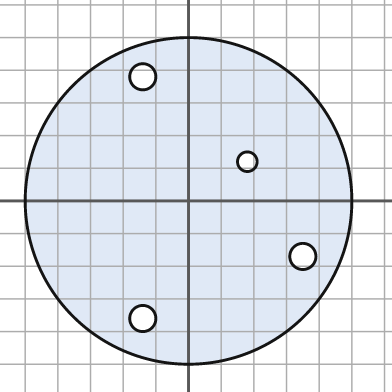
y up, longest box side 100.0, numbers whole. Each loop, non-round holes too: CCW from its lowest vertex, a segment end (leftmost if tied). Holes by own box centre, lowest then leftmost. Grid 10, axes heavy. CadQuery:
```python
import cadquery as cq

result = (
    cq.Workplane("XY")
    .moveTo(0.0, 0.0)
    .circle(50.0)
    .moveTo(-14.0, -36.0)
    .circle(4.0)
    .moveTo(35.0, -17.0)
    .circle(4.0)
    .moveTo(18.0, 12.0)
    .circle(3.0)
    .moveTo(-14.0, 38.0)
    .circle(4.0)
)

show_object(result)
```